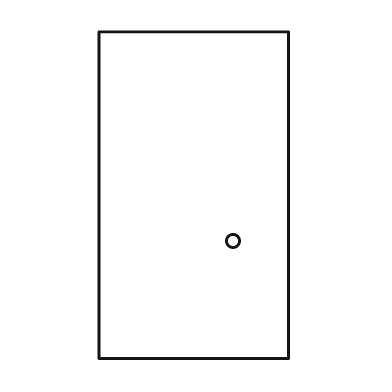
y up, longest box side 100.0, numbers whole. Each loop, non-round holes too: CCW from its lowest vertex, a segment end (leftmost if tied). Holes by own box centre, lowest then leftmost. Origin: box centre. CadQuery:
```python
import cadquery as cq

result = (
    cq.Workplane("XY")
    .moveTo(-29.0, -50.0)
    .lineTo(29.0, -50.0)
    .lineTo(29.0, 50.0)
    .lineTo(-29.0, 50.0)
    .close()
    .moveTo(12.0, -14.0)
    .circle(2.0)
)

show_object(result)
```